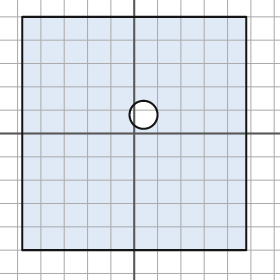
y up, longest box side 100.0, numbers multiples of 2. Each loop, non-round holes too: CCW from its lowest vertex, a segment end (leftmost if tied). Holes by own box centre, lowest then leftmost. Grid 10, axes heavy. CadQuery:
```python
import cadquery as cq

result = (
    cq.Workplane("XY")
    .moveTo(-48.0, -50.0)
    .lineTo(48.0, -50.0)
    .lineTo(48.0, 50.0)
    .lineTo(-48.0, 50.0)
    .close()
    .moveTo(4.0, 8.0)
    .circle(6.0)
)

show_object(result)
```